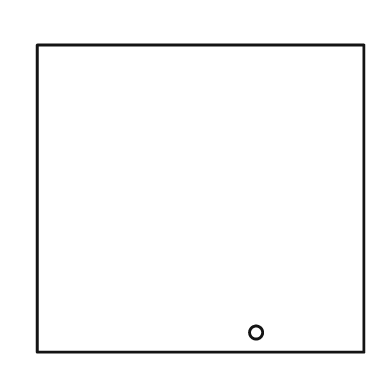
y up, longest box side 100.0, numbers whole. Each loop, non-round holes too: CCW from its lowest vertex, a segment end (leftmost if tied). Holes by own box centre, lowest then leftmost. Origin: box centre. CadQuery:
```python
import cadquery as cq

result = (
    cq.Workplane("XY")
    .moveTo(-50.0, -47.0)
    .lineTo(50.0, -47.0)
    .lineTo(50.0, 47.0)
    .lineTo(-50.0, 47.0)
    .close()
    .moveTo(17.0, -41.0)
    .circle(2.0)
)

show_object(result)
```